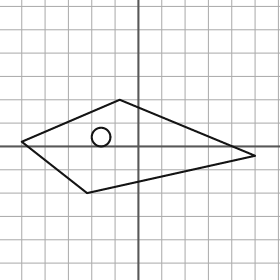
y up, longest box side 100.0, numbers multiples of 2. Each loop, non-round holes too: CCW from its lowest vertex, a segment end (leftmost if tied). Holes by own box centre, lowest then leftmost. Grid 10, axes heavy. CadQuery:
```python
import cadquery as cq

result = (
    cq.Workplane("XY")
    .moveTo(-22.0, -20.0)
    .lineTo(50.0, -4.0)
    .lineTo(-8.0, 20.0)
    .lineTo(-50.0, 2.0)
    .close()
    .moveTo(-16.0, 4.0)
    .circle(4.0)
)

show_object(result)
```